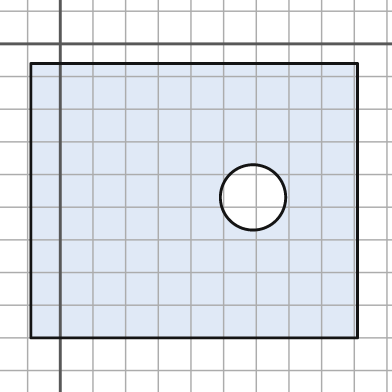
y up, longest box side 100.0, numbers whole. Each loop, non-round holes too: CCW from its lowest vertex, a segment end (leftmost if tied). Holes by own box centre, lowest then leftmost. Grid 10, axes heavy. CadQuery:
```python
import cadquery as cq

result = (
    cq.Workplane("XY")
    .moveTo(-9.0, -90.0)
    .lineTo(91.0, -90.0)
    .lineTo(91.0, -6.0)
    .lineTo(-9.0, -6.0)
    .close()
    .moveTo(59.0, -47.0)
    .circle(10.0)
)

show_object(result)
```